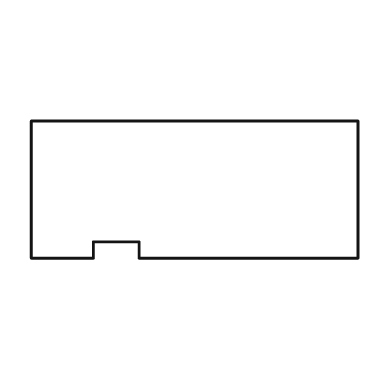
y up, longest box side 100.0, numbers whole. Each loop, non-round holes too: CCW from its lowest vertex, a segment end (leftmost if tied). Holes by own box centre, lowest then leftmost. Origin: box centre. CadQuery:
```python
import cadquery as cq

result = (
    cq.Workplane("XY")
    .moveTo(-50.0, -21.0)
    .lineTo(-31.0, -21.0)
    .lineTo(-31.0, -16.0)
    .lineTo(-17.0, -16.0)
    .lineTo(-17.0, -21.0)
    .lineTo(50.0, -21.0)
    .lineTo(50.0, 21.0)
    .lineTo(-50.0, 21.0)
    .close()
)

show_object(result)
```